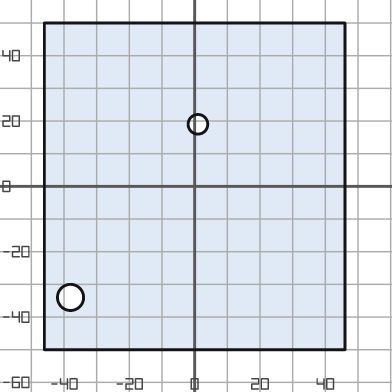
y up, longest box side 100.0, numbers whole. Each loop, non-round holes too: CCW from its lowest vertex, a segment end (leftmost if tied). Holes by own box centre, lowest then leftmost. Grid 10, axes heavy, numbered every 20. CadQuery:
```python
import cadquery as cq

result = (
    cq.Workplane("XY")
    .moveTo(-46.0, -50.0)
    .lineTo(46.0, -50.0)
    .lineTo(46.0, 50.0)
    .lineTo(-46.0, 50.0)
    .close()
    .moveTo(-38.0, -34.0)
    .circle(4.0)
    .moveTo(1.0, 19.0)
    .circle(3.0)
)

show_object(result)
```